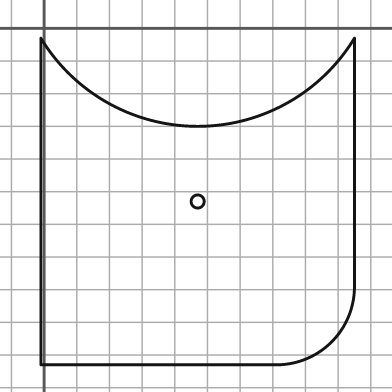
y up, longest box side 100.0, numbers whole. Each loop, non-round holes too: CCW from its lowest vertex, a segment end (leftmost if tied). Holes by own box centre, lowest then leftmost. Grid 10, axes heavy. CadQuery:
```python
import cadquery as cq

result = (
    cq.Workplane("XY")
    .moveTo(-1.0, -103.0)
    .lineTo(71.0, -103.0)
    .threePointArc((88.0, -96.0), (95.0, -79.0))
    .lineTo(95.0, -3.0)
    .threePointArc((47.0, -30.0), (-1.0, -3.0))
    .close()
    .moveTo(47.0, -53.0)
    .circle(2.0)
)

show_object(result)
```